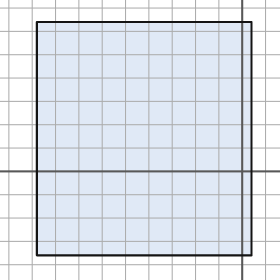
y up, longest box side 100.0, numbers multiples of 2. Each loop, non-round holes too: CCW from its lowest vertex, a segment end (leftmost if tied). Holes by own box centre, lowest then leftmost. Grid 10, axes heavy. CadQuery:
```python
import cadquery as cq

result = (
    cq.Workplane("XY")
    .moveTo(-88.0, -36.0)
    .lineTo(4.0, -36.0)
    .lineTo(4.0, 64.0)
    .lineTo(-88.0, 64.0)
    .close()
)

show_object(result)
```